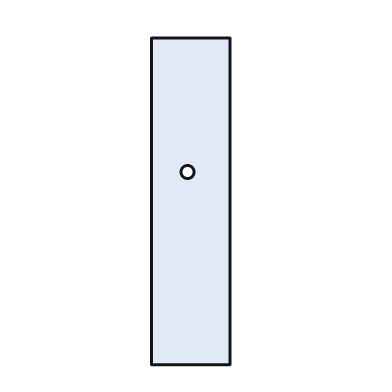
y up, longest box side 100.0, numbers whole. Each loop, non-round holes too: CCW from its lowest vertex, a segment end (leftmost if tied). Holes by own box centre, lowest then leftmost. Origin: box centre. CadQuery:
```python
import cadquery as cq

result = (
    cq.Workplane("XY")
    .moveTo(-12.0, -50.0)
    .lineTo(12.0, -50.0)
    .lineTo(12.0, 50.0)
    .lineTo(-12.0, 50.0)
    .close()
    .moveTo(-1.0, 9.0)
    .circle(2.0)
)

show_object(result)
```